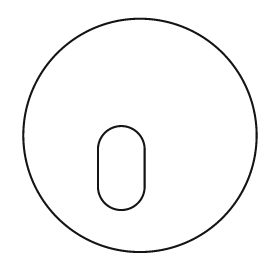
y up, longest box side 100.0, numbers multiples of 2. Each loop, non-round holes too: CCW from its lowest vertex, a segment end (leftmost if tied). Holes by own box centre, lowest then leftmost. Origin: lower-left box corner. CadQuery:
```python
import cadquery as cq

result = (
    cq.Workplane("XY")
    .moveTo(50.0, 50.0)
    .circle(50.0)
    .moveTo(32.0, 28.0)
    .threePointArc((42.0, 18.0), (52.0, 28.0))
    .lineTo(52.0, 44.0)
    .threePointArc((42.0, 54.0), (32.0, 44.0))
    .close()
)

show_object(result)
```